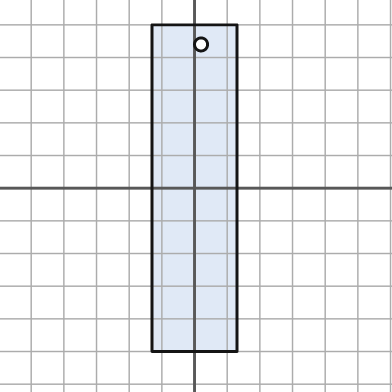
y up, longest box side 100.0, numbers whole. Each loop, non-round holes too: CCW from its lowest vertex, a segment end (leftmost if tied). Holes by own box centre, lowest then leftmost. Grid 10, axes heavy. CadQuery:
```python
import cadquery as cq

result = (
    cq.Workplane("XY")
    .moveTo(-13.0, -50.0)
    .lineTo(13.0, -50.0)
    .lineTo(13.0, 50.0)
    .lineTo(-13.0, 50.0)
    .close()
    .moveTo(2.0, 44.0)
    .circle(2.0)
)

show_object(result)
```